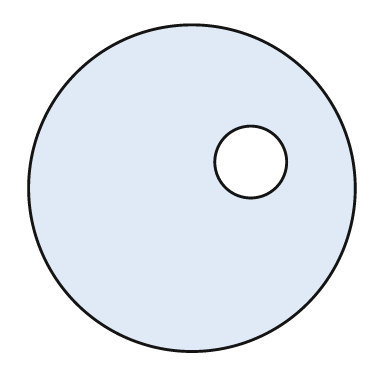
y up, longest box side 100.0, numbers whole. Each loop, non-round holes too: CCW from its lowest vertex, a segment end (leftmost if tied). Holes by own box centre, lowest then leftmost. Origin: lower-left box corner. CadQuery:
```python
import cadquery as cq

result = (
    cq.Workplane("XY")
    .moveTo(50.0, 50.0)
    .circle(50.0)
    .moveTo(68.0, 58.0)
    .circle(11.0)
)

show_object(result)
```